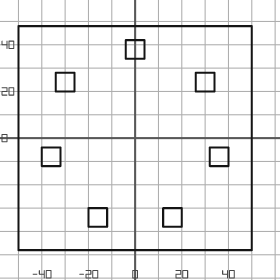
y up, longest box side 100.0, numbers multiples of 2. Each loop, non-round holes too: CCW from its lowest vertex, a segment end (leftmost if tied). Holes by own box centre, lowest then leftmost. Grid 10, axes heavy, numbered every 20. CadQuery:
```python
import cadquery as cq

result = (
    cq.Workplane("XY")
    .moveTo(-50.0, -48.0)
    .lineTo(50.0, -48.0)
    .lineTo(50.0, 48.0)
    .lineTo(-50.0, 48.0)
    .close()
    .moveTo(-20.0, -38.0)
    .lineTo(-12.0, -38.0)
    .lineTo(-12.0, -30.0)
    .lineTo(-20.0, -30.0)
    .close()
    .moveTo(12.0, -38.0)
    .lineTo(20.0, -38.0)
    .lineTo(20.0, -30.0)
    .lineTo(12.0, -30.0)
    .close()
    .moveTo(-40.0, -12.0)
    .lineTo(-32.0, -12.0)
    .lineTo(-32.0, -4.0)
    .lineTo(-40.0, -4.0)
    .close()
    .moveTo(32.0, -12.0)
    .lineTo(40.0, -12.0)
    .lineTo(40.0, -4.0)
    .lineTo(32.0, -4.0)
    .close()
    .moveTo(-34.0, 20.0)
    .lineTo(-26.0, 20.0)
    .lineTo(-26.0, 28.0)
    .lineTo(-34.0, 28.0)
    .close()
    .moveTo(26.0, 20.0)
    .lineTo(34.0, 20.0)
    .lineTo(34.0, 28.0)
    .lineTo(26.0, 28.0)
    .close()
    .moveTo(-4.0, 34.0)
    .lineTo(4.0, 34.0)
    .lineTo(4.0, 42.0)
    .lineTo(-4.0, 42.0)
    .close()
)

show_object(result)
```